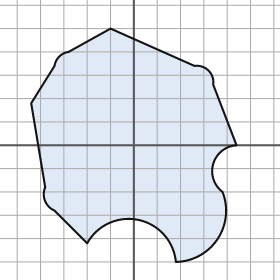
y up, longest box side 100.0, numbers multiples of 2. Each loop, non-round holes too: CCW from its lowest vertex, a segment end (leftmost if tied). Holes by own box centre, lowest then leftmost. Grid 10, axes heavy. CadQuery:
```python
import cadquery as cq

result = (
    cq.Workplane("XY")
    .moveTo(18.0, -50.0)
    .threePointArc((36.0, -40.0), (38.0, -20.0))
    .threePointArc((34.0, -8.0), (44.0, 0.0))
    .lineTo(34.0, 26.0)
    .threePointArc((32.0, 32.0), (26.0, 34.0))
    .lineTo(-10.0, 50.0)
    .lineTo(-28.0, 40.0)
    .threePointArc((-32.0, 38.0), (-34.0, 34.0))
    .lineTo(-44.0, 18.0)
    .lineTo(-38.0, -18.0)
    .threePointArc((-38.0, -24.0), (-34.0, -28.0))
    .lineTo(-20.0, -42.0)
    .threePointArc((2.0, -32.0), (18.0, -50.0))
    .close()
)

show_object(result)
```